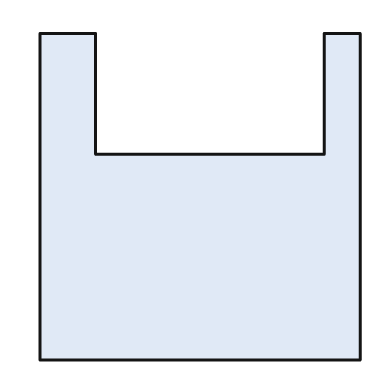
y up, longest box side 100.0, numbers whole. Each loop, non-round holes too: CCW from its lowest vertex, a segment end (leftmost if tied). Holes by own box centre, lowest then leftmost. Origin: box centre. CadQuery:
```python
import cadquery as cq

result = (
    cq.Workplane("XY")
    .moveTo(-49.0, -50.0)
    .lineTo(49.0, -50.0)
    .lineTo(49.0, 50.0)
    .lineTo(38.0, 50.0)
    .lineTo(38.0, 13.0)
    .lineTo(-32.0, 13.0)
    .lineTo(-32.0, 50.0)
    .lineTo(-49.0, 50.0)
    .close()
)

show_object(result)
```